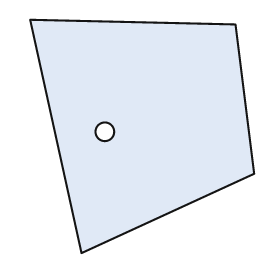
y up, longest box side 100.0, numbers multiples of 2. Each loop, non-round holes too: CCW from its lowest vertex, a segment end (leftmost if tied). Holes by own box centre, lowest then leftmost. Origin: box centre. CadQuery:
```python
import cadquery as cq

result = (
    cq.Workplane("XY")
    .moveTo(-26.0, -50.0)
    .lineTo(48.0, -16.0)
    .lineTo(40.0, 48.0)
    .lineTo(-48.0, 50.0)
    .close()
    .moveTo(-16.0, 2.0)
    .circle(4.0)
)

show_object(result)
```